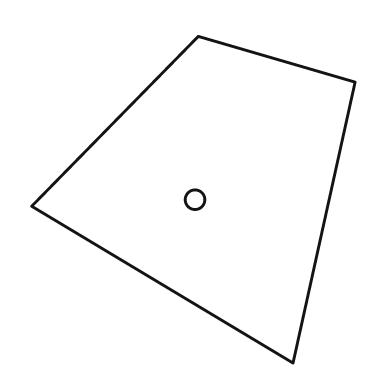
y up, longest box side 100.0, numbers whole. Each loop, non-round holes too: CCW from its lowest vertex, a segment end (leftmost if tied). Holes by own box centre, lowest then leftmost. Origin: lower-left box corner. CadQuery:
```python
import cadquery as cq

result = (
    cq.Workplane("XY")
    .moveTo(80.0, 0.0)
    .lineTo(99.0, 86.0)
    .lineTo(51.0, 100.0)
    .lineTo(0.0, 48.0)
    .close()
    .moveTo(50.0, 50.0)
    .circle(3.0)
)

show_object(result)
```